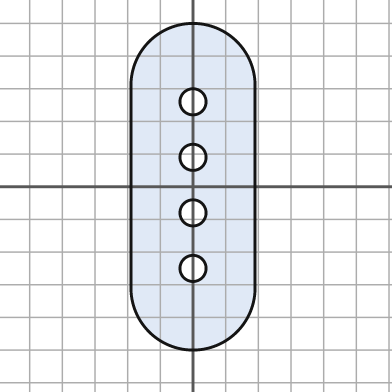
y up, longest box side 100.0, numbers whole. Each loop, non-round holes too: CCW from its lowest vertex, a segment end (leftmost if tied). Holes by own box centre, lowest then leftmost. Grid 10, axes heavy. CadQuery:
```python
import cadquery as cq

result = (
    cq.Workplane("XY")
    .moveTo(-19.0, -31.0)
    .threePointArc((0.0, -50.0), (19.0, -31.0))
    .lineTo(19.0, 31.0)
    .threePointArc((0.0, 50.0), (-19.0, 31.0))
    .close()
    .moveTo(0.0, -25.0)
    .circle(4.0)
    .moveTo(0.0, -8.0)
    .circle(4.0)
    .moveTo(0.0, 9.0)
    .circle(4.0)
    .moveTo(0.0, 26.0)
    .circle(4.0)
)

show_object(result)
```